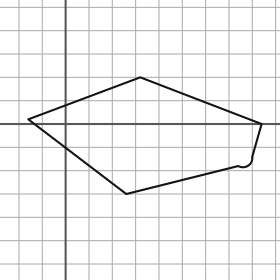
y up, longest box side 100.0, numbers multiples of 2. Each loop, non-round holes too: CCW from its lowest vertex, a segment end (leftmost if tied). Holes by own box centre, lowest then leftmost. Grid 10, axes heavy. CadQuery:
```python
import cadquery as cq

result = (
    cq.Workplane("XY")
    .moveTo(26.0, -30.0)
    .lineTo(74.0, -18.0)
    .threePointArc((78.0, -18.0), (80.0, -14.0))
    .lineTo(84.0, 0.0)
    .lineTo(32.0, 20.0)
    .lineTo(-16.0, 2.0)
    .close()
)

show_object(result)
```